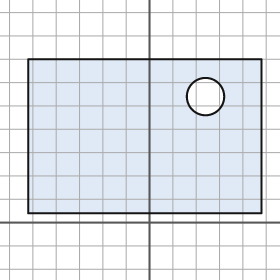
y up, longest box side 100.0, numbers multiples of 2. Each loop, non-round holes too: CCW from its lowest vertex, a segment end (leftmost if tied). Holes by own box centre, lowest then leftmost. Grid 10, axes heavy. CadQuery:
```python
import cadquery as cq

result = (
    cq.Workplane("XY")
    .moveTo(-52.0, 4.0)
    .lineTo(48.0, 4.0)
    .lineTo(48.0, 70.0)
    .lineTo(-52.0, 70.0)
    .close()
    .moveTo(24.0, 54.0)
    .circle(8.0)
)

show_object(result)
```